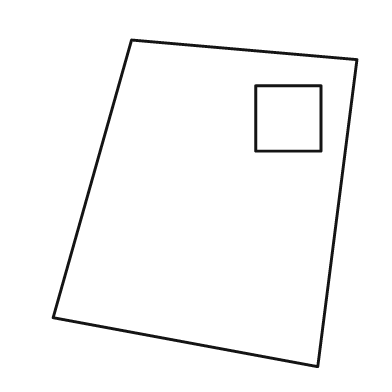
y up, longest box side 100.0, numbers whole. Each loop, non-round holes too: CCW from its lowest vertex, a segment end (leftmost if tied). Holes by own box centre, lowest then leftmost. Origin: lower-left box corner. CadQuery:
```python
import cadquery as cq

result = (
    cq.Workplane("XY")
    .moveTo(81.0, 0.0)
    .lineTo(93.0, 94.0)
    .lineTo(24.0, 100.0)
    .lineTo(0.0, 15.0)
    .close()
    .moveTo(62.0, 66.0)
    .lineTo(82.0, 66.0)
    .lineTo(82.0, 86.0)
    .lineTo(62.0, 86.0)
    .close()
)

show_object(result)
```